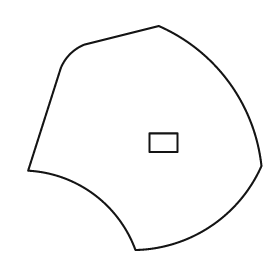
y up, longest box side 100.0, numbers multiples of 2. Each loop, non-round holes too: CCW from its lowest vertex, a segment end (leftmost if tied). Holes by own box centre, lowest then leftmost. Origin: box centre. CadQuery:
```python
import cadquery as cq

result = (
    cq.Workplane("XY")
    .moveTo(-4.0, -48.0)
    .threePointArc((28.0, -38.0), (50.0, -12.0))
    .threePointArc((36.0, 24.0), (6.0, 48.0))
    .lineTo(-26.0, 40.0)
    .threePointArc((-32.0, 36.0), (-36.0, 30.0))
    .lineTo(-50.0, -14.0)
    .threePointArc((-22.0, -24.0), (-4.0, -48.0))
    .close()
    .moveTo(2.0, -6.0)
    .lineTo(14.0, -6.0)
    .lineTo(14.0, 2.0)
    .lineTo(2.0, 2.0)
    .close()
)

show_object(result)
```